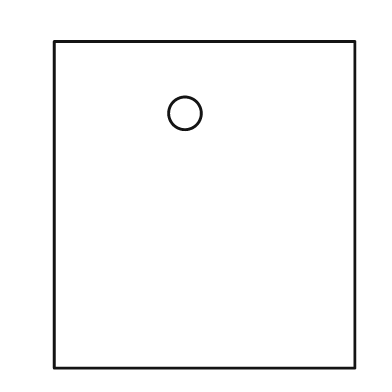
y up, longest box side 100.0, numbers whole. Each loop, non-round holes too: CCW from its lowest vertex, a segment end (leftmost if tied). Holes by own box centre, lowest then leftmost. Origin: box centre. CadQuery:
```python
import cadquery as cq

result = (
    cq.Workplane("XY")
    .moveTo(-46.0, -50.0)
    .lineTo(46.0, -50.0)
    .lineTo(46.0, 50.0)
    .lineTo(-46.0, 50.0)
    .close()
    .moveTo(-6.0, 28.0)
    .circle(5.0)
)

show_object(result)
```